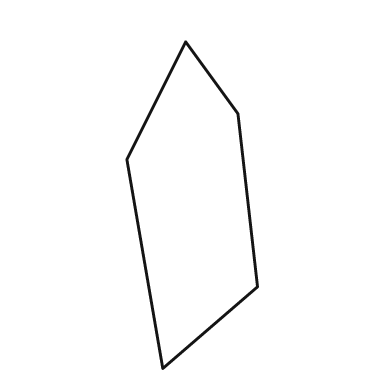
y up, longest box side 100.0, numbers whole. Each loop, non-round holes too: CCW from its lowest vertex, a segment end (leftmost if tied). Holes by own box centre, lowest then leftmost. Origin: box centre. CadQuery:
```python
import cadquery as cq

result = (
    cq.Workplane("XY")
    .moveTo(-9.0, -50.0)
    .lineTo(20.0, -25.0)
    .lineTo(14.0, 28.0)
    .lineTo(-2.0, 50.0)
    .lineTo(-20.0, 14.0)
    .close()
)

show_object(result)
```